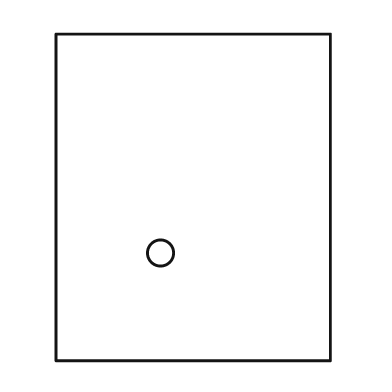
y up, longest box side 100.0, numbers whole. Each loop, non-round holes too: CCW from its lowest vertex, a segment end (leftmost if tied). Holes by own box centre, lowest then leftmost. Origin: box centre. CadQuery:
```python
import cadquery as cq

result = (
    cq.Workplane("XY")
    .moveTo(-42.0, -50.0)
    .lineTo(42.0, -50.0)
    .lineTo(42.0, 50.0)
    .lineTo(-42.0, 50.0)
    .close()
    .moveTo(-10.0, -17.0)
    .circle(4.0)
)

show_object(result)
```